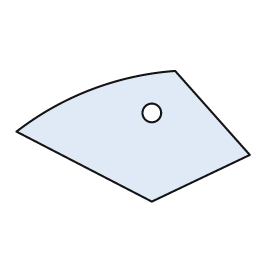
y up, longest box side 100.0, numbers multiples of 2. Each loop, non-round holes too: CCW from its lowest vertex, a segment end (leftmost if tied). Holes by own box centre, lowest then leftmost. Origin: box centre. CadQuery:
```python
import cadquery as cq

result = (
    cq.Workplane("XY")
    .moveTo(8.0, -28.0)
    .lineTo(50.0, -8.0)
    .lineTo(18.0, 28.0)
    .threePointArc((-18.0, 20.0), (-50.0, 2.0))
    .close()
    .moveTo(8.0, 10.0)
    .circle(4.0)
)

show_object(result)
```